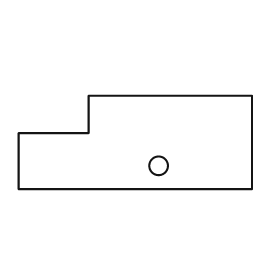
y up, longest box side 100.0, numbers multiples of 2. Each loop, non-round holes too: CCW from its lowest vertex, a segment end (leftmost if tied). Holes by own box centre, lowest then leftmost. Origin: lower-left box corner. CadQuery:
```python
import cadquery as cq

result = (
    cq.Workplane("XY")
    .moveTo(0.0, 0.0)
    .lineTo(100.0, 0.0)
    .lineTo(100.0, 40.0)
    .lineTo(30.0, 40.0)
    .lineTo(30.0, 24.0)
    .lineTo(0.0, 24.0)
    .close()
    .moveTo(60.0, 10.0)
    .circle(4.0)
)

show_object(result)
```